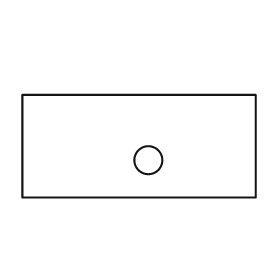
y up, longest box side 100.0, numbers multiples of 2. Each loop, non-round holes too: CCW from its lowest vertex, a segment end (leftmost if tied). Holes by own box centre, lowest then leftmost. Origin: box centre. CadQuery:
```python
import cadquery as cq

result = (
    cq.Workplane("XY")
    .moveTo(-50.0, -22.0)
    .lineTo(50.0, -22.0)
    .lineTo(50.0, 22.0)
    .lineTo(-50.0, 22.0)
    .close()
    .moveTo(4.0, -6.0)
    .circle(6.0)
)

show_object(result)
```